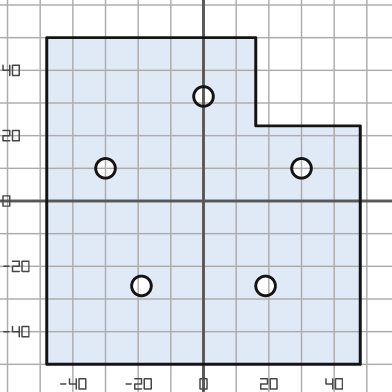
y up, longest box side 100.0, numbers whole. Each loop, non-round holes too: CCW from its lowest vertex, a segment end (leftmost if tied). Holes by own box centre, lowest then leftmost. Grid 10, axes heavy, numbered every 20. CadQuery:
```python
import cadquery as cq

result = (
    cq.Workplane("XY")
    .moveTo(-48.0, -50.0)
    .lineTo(48.0, -50.0)
    .lineTo(48.0, 23.0)
    .lineTo(16.0, 23.0)
    .lineTo(16.0, 50.0)
    .lineTo(-48.0, 50.0)
    .close()
    .moveTo(-19.0, -26.0)
    .circle(3.0)
    .moveTo(19.0, -26.0)
    .circle(3.0)
    .moveTo(-30.0, 10.0)
    .circle(3.0)
    .moveTo(30.0, 10.0)
    .circle(3.0)
    .moveTo(0.0, 32.0)
    .circle(3.0)
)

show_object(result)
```